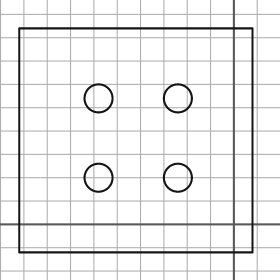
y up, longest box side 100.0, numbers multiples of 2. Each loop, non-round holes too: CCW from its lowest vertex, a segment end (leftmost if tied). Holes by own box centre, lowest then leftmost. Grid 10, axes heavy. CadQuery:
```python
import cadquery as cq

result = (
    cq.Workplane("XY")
    .moveTo(-92.0, -12.0)
    .lineTo(8.0, -12.0)
    .lineTo(8.0, 84.0)
    .lineTo(-92.0, 84.0)
    .close()
    .moveTo(-58.0, 20.0)
    .circle(6.0)
    .moveTo(-24.0, 20.0)
    .circle(6.0)
    .moveTo(-58.0, 54.0)
    .circle(6.0)
    .moveTo(-24.0, 54.0)
    .circle(6.0)
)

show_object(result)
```